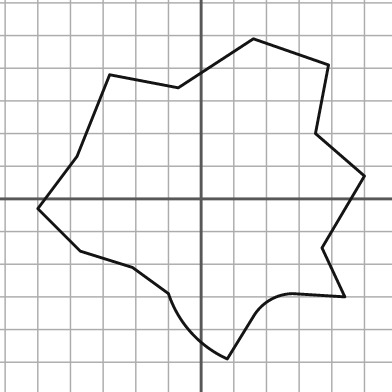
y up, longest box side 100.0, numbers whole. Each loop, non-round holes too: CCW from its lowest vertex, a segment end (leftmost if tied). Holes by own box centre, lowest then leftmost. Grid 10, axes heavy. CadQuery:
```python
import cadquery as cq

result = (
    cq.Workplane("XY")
    .moveTo(8.0, -49.0)
    .lineTo(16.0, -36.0)
    .threePointArc((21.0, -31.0), (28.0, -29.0))
    .lineTo(44.0, -30.0)
    .lineTo(37.0, -15.0)
    .lineTo(50.0, 7.0)
    .lineTo(35.0, 20.0)
    .lineTo(39.0, 41.0)
    .lineTo(16.0, 49.0)
    .lineTo(-7.0, 34.0)
    .lineTo(-28.0, 38.0)
    .lineTo(-38.0, 13.0)
    .lineTo(-50.0, -3.0)
    .lineTo(-37.0, -16.0)
    .lineTo(-21.0, -21.0)
    .lineTo(-10.0, -29.0)
    .threePointArc((-3.0, -41.0), (8.0, -49.0))
    .close()
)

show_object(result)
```